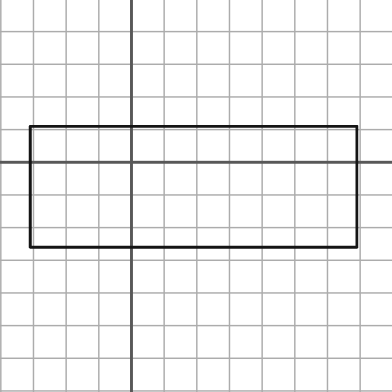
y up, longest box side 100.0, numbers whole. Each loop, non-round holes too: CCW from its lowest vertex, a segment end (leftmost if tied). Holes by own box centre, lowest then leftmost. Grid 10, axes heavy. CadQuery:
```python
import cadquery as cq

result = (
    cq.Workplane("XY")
    .moveTo(-31.0, -26.0)
    .lineTo(69.0, -26.0)
    .lineTo(69.0, 11.0)
    .lineTo(-31.0, 11.0)
    .close()
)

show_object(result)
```